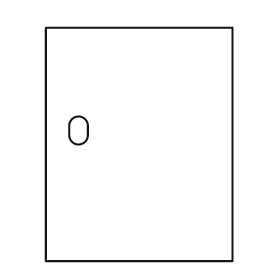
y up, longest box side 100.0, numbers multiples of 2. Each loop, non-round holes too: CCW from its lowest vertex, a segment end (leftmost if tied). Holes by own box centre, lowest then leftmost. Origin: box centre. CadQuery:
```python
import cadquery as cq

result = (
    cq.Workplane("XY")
    .moveTo(-40.0, -50.0)
    .lineTo(40.0, -50.0)
    .lineTo(40.0, 50.0)
    .lineTo(-40.0, 50.0)
    .close()
    .moveTo(-30.0, 4.0)
    .threePointArc((-26.0, 0.0), (-22.0, 4.0))
    .lineTo(-22.0, 8.0)
    .threePointArc((-26.0, 12.0), (-30.0, 8.0))
    .close()
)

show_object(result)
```